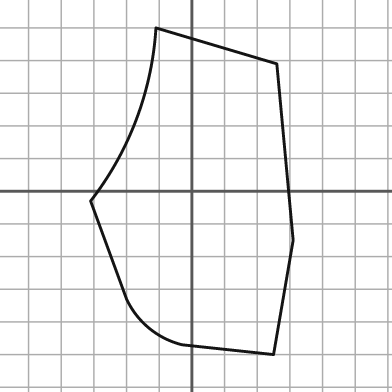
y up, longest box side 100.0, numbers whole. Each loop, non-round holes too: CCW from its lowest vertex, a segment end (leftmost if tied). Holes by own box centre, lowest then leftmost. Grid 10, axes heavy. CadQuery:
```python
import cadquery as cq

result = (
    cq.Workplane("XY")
    .moveTo(25.0, -50.0)
    .lineTo(31.0, -15.0)
    .lineTo(26.0, 39.0)
    .lineTo(-11.0, 50.0)
    .threePointArc((-17.0, 22.0), (-31.0, -3.0))
    .lineTo(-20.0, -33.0)
    .threePointArc((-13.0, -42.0), (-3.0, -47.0))
    .close()
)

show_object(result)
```